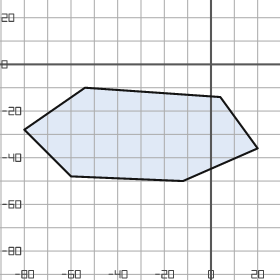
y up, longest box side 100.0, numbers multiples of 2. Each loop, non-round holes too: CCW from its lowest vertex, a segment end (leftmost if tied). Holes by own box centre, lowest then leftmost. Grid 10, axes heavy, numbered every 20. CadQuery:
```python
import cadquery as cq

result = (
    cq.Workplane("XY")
    .moveTo(-12.0, -50.0)
    .lineTo(20.0, -36.0)
    .lineTo(4.0, -14.0)
    .lineTo(-54.0, -10.0)
    .lineTo(-80.0, -28.0)
    .lineTo(-60.0, -48.0)
    .close()
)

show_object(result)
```